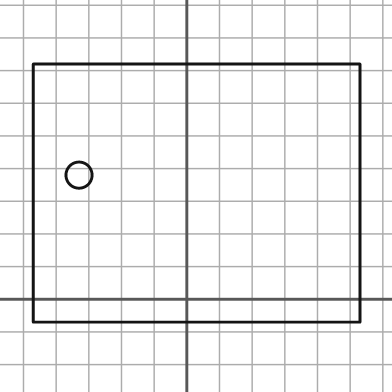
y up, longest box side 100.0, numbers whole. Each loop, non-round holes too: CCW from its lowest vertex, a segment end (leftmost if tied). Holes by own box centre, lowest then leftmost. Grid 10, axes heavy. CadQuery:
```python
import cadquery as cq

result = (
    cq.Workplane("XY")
    .moveTo(-47.0, -7.0)
    .lineTo(53.0, -7.0)
    .lineTo(53.0, 72.0)
    .lineTo(-47.0, 72.0)
    .close()
    .moveTo(-33.0, 38.0)
    .circle(4.0)
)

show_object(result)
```